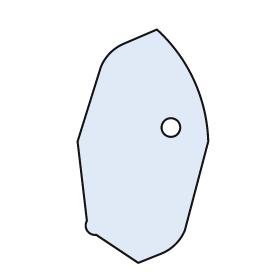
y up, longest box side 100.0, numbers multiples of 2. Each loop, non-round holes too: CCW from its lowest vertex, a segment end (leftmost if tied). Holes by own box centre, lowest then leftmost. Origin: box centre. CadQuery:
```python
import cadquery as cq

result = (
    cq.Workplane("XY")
    .moveTo(-2.0, -50.0)
    .lineTo(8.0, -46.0)
    .threePointArc((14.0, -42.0), (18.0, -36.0))
    .lineTo(28.0, 2.0)
    .threePointArc((22.0, 28.0), (6.0, 50.0))
    .lineTo(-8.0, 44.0)
    .threePointArc((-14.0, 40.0), (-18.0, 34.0))
    .lineTo(-28.0, 2.0)
    .lineTo(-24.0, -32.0)
    .threePointArc((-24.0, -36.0), (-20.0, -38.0))
    .close()
    .moveTo(12.0, 8.0)
    .circle(4.0)
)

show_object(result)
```